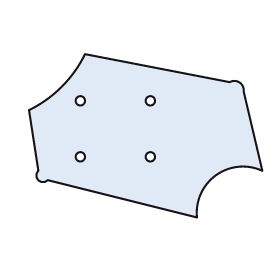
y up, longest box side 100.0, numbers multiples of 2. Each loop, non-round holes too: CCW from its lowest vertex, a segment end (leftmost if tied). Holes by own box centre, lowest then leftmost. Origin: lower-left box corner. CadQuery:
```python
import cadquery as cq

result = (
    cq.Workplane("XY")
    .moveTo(72.0, 0.0)
    .threePointArc((80.0, 18.0), (100.0, 20.0))
    .lineTo(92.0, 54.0)
    .threePointArc((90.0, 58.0), (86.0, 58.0))
    .lineTo(24.0, 70.0)
    .threePointArc((14.0, 56.0), (0.0, 46.0))
    .lineTo(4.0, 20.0)
    .threePointArc((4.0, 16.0), (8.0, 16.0))
    .close()
    .moveTo(22.0, 26.0)
    .circle(2.0)
    .moveTo(52.0, 26.0)
    .circle(2.0)
    .moveTo(22.0, 50.0)
    .circle(2.0)
    .moveTo(52.0, 50.0)
    .circle(2.0)
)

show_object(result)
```